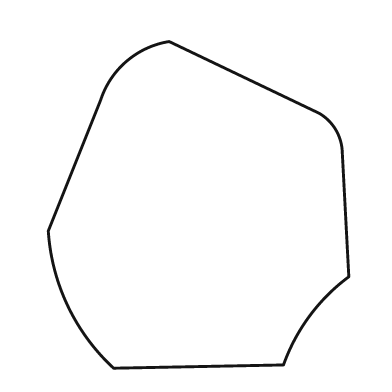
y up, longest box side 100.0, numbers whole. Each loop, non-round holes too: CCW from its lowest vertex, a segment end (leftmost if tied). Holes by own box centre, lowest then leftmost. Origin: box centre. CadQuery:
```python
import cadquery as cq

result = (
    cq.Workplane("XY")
    .moveTo(-26.0, -50.0)
    .lineTo(26.0, -49.0)
    .threePointArc((34.0, -34.0), (46.0, -22.0))
    .lineTo(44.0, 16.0)
    .threePointArc((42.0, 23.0), (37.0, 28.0))
    .lineTo(-9.0, 50.0)
    .threePointArc((-22.0, 44.0), (-30.0, 32.0))
    .lineTo(-46.0, -8.0)
    .threePointArc((-40.0, -31.0), (-26.0, -50.0))
    .close()
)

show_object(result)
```